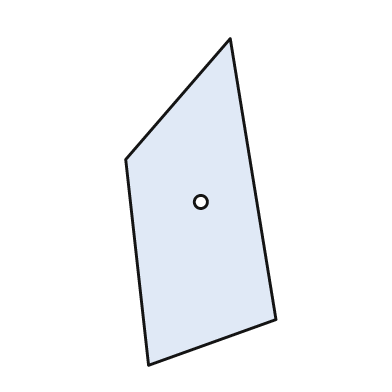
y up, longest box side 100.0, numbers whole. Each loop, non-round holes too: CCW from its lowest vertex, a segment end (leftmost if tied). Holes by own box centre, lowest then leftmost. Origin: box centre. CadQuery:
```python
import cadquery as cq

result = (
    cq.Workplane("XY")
    .moveTo(-16.0, -50.0)
    .lineTo(23.0, -36.0)
    .lineTo(9.0, 50.0)
    .lineTo(-23.0, 13.0)
    .close()
    .moveTo(0.0, 0.0)
    .circle(2.0)
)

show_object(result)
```